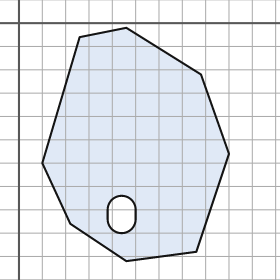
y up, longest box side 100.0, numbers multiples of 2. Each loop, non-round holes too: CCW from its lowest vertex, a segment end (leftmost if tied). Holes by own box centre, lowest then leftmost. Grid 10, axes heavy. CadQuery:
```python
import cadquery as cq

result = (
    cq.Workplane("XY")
    .moveTo(46.0, -102.0)
    .lineTo(76.0, -98.0)
    .lineTo(90.0, -56.0)
    .lineTo(78.0, -22.0)
    .lineTo(46.0, -2.0)
    .lineTo(26.0, -6.0)
    .lineTo(10.0, -60.0)
    .lineTo(22.0, -86.0)
    .close()
    .moveTo(38.0, -84.0)
    .threePointArc((44.0, -90.0), (50.0, -84.0))
    .lineTo(50.0, -80.0)
    .threePointArc((44.0, -74.0), (38.0, -80.0))
    .close()
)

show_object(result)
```